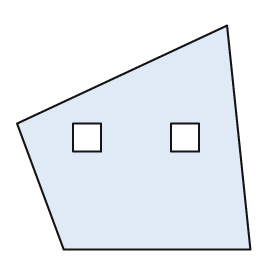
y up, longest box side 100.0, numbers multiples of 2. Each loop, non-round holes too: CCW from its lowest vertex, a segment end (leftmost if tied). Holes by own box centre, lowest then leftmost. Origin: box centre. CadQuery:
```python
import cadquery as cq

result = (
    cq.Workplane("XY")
    .moveTo(-30.0, -48.0)
    .lineTo(50.0, -48.0)
    .lineTo(40.0, 48.0)
    .lineTo(-50.0, 6.0)
    .close()
    .moveTo(-26.0, -6.0)
    .lineTo(-14.0, -6.0)
    .lineTo(-14.0, 6.0)
    .lineTo(-26.0, 6.0)
    .close()
    .moveTo(16.0, -6.0)
    .lineTo(28.0, -6.0)
    .lineTo(28.0, 6.0)
    .lineTo(16.0, 6.0)
    .close()
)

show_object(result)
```